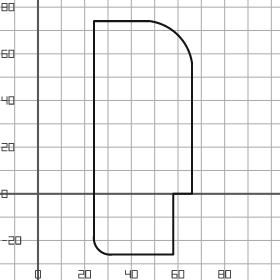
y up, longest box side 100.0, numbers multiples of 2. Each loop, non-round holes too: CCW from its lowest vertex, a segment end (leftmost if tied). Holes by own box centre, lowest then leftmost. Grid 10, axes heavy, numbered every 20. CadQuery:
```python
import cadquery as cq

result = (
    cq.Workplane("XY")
    .moveTo(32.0, -26.0)
    .lineTo(58.0, -26.0)
    .lineTo(58.0, 0.0)
    .lineTo(66.0, 0.0)
    .lineTo(66.0, 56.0)
    .threePointArc((60.0, 68.0), (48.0, 74.0))
    .lineTo(24.0, 74.0)
    .lineTo(24.0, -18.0)
    .threePointArc((26.0, -24.0), (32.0, -26.0))
    .close()
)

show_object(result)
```